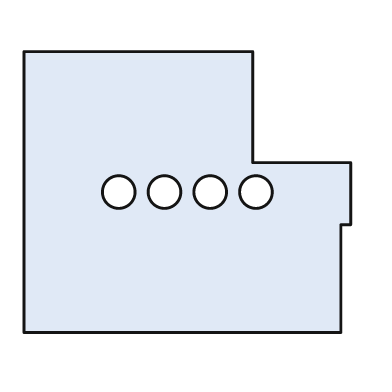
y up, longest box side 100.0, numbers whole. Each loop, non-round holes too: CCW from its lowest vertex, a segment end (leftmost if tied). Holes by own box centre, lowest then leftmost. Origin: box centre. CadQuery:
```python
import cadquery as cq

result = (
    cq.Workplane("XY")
    .moveTo(-50.0, -43.0)
    .lineTo(47.0, -43.0)
    .lineTo(47.0, -10.0)
    .lineTo(50.0, -10.0)
    .lineTo(50.0, 9.0)
    .lineTo(20.0, 9.0)
    .lineTo(20.0, 43.0)
    .lineTo(-50.0, 43.0)
    .close()
    .moveTo(-21.0, 0.0)
    .circle(5.0)
    .moveTo(-7.0, 0.0)
    .circle(5.0)
    .moveTo(7.0, 0.0)
    .circle(5.0)
    .moveTo(21.0, 0.0)
    .circle(5.0)
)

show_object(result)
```